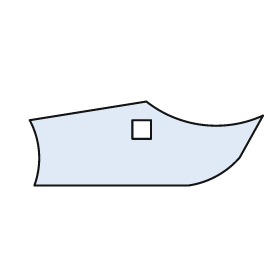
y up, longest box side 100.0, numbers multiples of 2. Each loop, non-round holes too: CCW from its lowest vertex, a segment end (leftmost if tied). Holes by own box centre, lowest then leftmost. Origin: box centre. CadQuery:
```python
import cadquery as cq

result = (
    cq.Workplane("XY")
    .moveTo(-48.0, -18.0)
    .lineTo(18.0, -18.0)
    .threePointArc((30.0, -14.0), (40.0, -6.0))
    .lineTo(50.0, 12.0)
    .threePointArc((24.0, 8.0), (0.0, 18.0))
    .lineTo(-50.0, 10.0)
    .threePointArc((-46.0, -4.0), (-48.0, -18.0))
    .close()
    .moveTo(-6.0, 2.0)
    .lineTo(2.0, 2.0)
    .lineTo(2.0, 10.0)
    .lineTo(-6.0, 10.0)
    .close()
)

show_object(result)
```